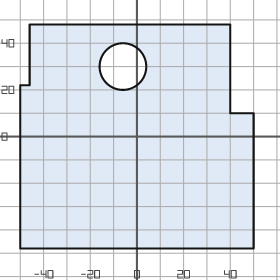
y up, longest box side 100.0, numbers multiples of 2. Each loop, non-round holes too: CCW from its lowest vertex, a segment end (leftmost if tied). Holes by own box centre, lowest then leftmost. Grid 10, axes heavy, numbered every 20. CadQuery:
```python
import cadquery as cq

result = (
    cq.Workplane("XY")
    .moveTo(-50.0, -48.0)
    .lineTo(50.0, -48.0)
    .lineTo(50.0, 10.0)
    .lineTo(40.0, 10.0)
    .lineTo(40.0, 48.0)
    .lineTo(-46.0, 48.0)
    .lineTo(-46.0, 22.0)
    .lineTo(-50.0, 22.0)
    .close()
    .moveTo(-6.0, 30.0)
    .circle(10.0)
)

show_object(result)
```